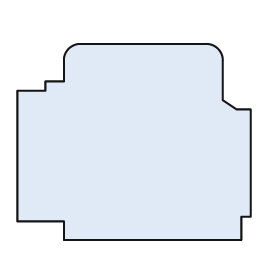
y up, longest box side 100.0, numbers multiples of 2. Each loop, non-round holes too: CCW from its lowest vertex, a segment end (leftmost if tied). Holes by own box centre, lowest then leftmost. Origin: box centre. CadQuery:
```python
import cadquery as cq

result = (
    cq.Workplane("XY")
    .moveTo(-30.0, -42.0)
    .lineTo(46.0, -42.0)
    .lineTo(46.0, -32.0)
    .lineTo(50.0, -32.0)
    .lineTo(50.0, 14.0)
    .lineTo(44.0, 14.0)
    .lineTo(38.0, 18.0)
    .lineTo(38.0, 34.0)
    .threePointArc((36.0, 40.0), (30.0, 42.0))
    .lineTo(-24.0, 42.0)
    .threePointArc((-28.0, 40.0), (-30.0, 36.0))
    .lineTo(-30.0, 26.0)
    .lineTo(-38.0, 26.0)
    .lineTo(-38.0, 22.0)
    .lineTo(-50.0, 22.0)
    .lineTo(-50.0, -34.0)
    .lineTo(-30.0, -34.0)
    .close()
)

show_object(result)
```